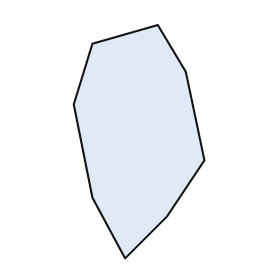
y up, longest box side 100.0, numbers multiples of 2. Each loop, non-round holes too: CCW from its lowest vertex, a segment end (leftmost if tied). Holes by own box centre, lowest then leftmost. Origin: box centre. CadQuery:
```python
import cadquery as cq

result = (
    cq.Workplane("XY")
    .moveTo(-6.0, -50.0)
    .lineTo(12.0, -32.0)
    .lineTo(28.0, -8.0)
    .lineTo(20.0, 30.0)
    .lineTo(8.0, 50.0)
    .lineTo(-20.0, 42.0)
    .lineTo(-28.0, 16.0)
    .lineTo(-20.0, -24.0)
    .close()
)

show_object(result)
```